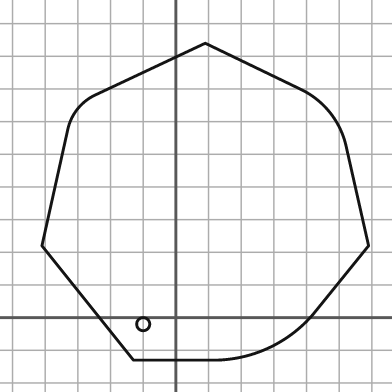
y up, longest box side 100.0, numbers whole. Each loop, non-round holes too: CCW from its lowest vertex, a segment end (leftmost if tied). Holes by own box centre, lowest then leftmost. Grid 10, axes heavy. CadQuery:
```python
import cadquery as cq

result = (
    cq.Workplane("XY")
    .moveTo(-13.0, -13.0)
    .lineTo(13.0, -13.0)
    .threePointArc((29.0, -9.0), (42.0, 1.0))
    .lineTo(59.0, 22.0)
    .lineTo(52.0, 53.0)
    .threePointArc((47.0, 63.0), (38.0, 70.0))
    .lineTo(9.0, 84.0)
    .lineTo(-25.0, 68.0)
    .threePointArc((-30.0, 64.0), (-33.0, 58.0))
    .lineTo(-41.0, 22.0)
    .close()
    .moveTo(-10.0, -2.0)
    .circle(2.0)
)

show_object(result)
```